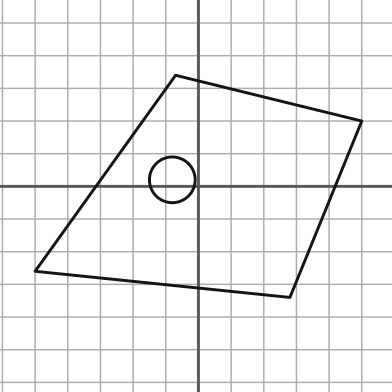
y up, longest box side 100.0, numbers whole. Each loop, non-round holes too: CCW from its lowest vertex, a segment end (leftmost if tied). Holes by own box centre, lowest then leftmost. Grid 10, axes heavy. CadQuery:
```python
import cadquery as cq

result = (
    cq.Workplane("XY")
    .moveTo(28.0, -34.0)
    .lineTo(50.0, 20.0)
    .lineTo(-7.0, 34.0)
    .lineTo(-50.0, -26.0)
    .close()
    .moveTo(-8.0, 2.0)
    .circle(7.0)
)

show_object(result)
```